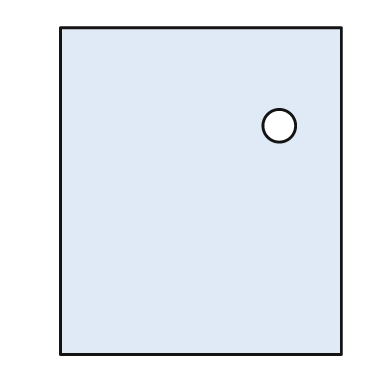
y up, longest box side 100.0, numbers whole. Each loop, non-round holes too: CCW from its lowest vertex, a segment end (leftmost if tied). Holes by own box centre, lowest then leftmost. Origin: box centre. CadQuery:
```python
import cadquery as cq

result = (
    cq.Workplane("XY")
    .moveTo(-43.0, -50.0)
    .lineTo(43.0, -50.0)
    .lineTo(43.0, 50.0)
    .lineTo(-43.0, 50.0)
    .close()
    .moveTo(24.0, 20.0)
    .circle(5.0)
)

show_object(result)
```